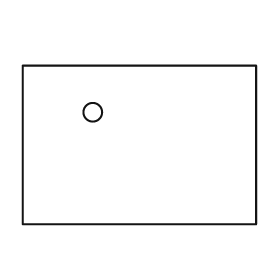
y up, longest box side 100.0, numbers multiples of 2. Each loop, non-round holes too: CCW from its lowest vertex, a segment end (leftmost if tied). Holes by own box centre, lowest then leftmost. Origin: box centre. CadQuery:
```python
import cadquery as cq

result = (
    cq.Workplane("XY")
    .moveTo(-50.0, -34.0)
    .lineTo(50.0, -34.0)
    .lineTo(50.0, 34.0)
    .lineTo(-50.0, 34.0)
    .close()
    .moveTo(-20.0, 14.0)
    .circle(4.0)
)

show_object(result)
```